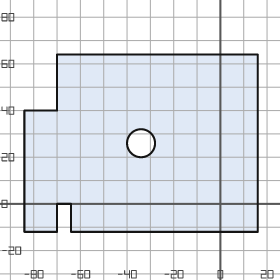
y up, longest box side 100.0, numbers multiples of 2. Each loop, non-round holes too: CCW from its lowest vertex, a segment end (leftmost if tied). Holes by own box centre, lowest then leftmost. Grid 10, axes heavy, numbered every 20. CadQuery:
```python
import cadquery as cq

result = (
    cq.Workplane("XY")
    .moveTo(-84.0, -12.0)
    .lineTo(-70.0, -12.0)
    .lineTo(-70.0, 0.0)
    .lineTo(-64.0, 0.0)
    .lineTo(-64.0, -12.0)
    .lineTo(16.0, -12.0)
    .lineTo(16.0, 64.0)
    .lineTo(-70.0, 64.0)
    .lineTo(-70.0, 40.0)
    .lineTo(-84.0, 40.0)
    .close()
    .moveTo(-34.0, 26.0)
    .circle(6.0)
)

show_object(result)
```